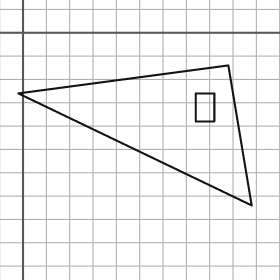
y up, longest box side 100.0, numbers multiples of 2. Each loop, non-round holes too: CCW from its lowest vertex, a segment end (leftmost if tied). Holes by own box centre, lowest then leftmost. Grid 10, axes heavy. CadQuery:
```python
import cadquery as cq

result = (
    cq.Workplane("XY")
    .moveTo(98.0, -74.0)
    .lineTo(88.0, -14.0)
    .lineTo(-2.0, -26.0)
    .close()
    .moveTo(74.0, -38.0)
    .lineTo(82.0, -38.0)
    .lineTo(82.0, -26.0)
    .lineTo(74.0, -26.0)
    .close()
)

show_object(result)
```